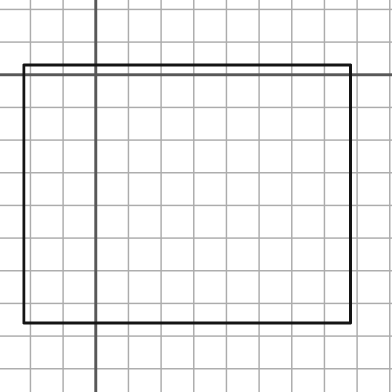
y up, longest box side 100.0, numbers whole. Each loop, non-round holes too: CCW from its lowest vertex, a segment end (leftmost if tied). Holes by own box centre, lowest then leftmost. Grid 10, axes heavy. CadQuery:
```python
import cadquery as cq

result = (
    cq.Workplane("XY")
    .moveTo(-22.0, -76.0)
    .lineTo(78.0, -76.0)
    .lineTo(78.0, 3.0)
    .lineTo(-22.0, 3.0)
    .close()
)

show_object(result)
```